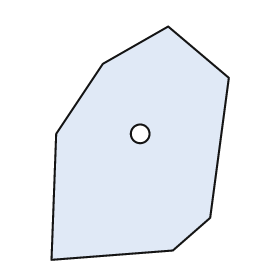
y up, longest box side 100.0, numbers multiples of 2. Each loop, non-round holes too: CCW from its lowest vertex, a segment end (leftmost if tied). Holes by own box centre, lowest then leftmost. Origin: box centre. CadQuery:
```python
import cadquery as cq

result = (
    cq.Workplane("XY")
    .moveTo(-38.0, -50.0)
    .lineTo(14.0, -46.0)
    .lineTo(30.0, -32.0)
    .lineTo(38.0, 28.0)
    .lineTo(12.0, 50.0)
    .lineTo(-16.0, 34.0)
    .lineTo(-36.0, 4.0)
    .close()
    .moveTo(0.0, 4.0)
    .circle(4.0)
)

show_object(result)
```